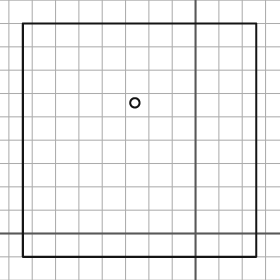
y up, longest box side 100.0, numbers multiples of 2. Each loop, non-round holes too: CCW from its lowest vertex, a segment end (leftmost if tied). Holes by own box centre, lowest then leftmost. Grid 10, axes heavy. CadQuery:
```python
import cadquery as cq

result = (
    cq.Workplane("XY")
    .moveTo(-74.0, -10.0)
    .lineTo(26.0, -10.0)
    .lineTo(26.0, 90.0)
    .lineTo(-74.0, 90.0)
    .close()
    .moveTo(-26.0, 56.0)
    .circle(2.0)
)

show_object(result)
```